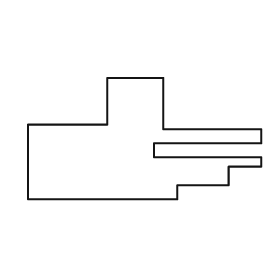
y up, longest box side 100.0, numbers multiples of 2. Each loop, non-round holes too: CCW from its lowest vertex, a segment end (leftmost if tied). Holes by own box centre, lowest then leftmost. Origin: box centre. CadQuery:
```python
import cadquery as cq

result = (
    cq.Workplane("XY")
    .moveTo(-50.0, -26.0)
    .lineTo(14.0, -26.0)
    .lineTo(14.0, -20.0)
    .lineTo(36.0, -20.0)
    .lineTo(36.0, -12.0)
    .lineTo(50.0, -12.0)
    .lineTo(50.0, -8.0)
    .lineTo(4.0, -8.0)
    .lineTo(4.0, -2.0)
    .lineTo(50.0, -2.0)
    .lineTo(50.0, 4.0)
    .lineTo(8.0, 4.0)
    .lineTo(8.0, 26.0)
    .lineTo(-16.0, 26.0)
    .lineTo(-16.0, 6.0)
    .lineTo(-50.0, 6.0)
    .close()
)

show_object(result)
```